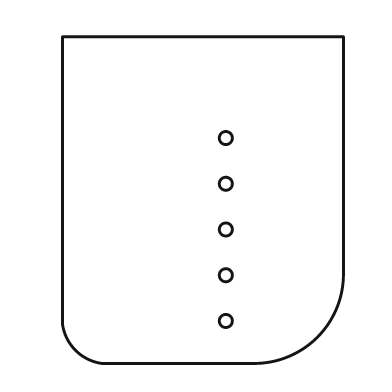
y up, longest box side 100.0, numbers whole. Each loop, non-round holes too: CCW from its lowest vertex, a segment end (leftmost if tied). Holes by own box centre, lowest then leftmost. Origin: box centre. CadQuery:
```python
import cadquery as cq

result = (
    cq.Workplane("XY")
    .moveTo(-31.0, -50.0)
    .lineTo(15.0, -50.0)
    .threePointArc((35.0, -42.0), (43.0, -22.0))
    .lineTo(43.0, 50.0)
    .lineTo(-43.0, 50.0)
    .lineTo(-43.0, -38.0)
    .threePointArc((-39.0, -46.0), (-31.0, -50.0))
    .close()
    .moveTo(7.0, -37.0)
    .circle(2.0)
    .moveTo(7.0, -23.0)
    .circle(2.0)
    .moveTo(7.0, -9.0)
    .circle(2.0)
    .moveTo(7.0, 5.0)
    .circle(2.0)
    .moveTo(7.0, 19.0)
    .circle(2.0)
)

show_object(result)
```